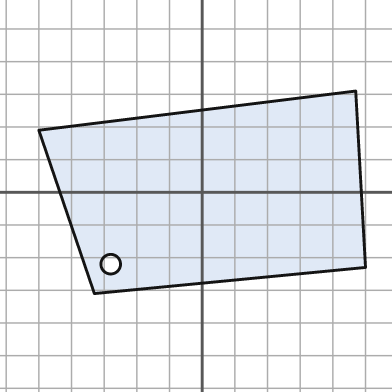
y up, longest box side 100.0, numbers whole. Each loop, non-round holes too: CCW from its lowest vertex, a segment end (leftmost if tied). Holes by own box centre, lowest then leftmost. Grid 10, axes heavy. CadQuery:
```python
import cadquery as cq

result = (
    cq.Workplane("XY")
    .moveTo(-33.0, -31.0)
    .lineTo(50.0, -23.0)
    .lineTo(47.0, 31.0)
    .lineTo(-50.0, 19.0)
    .close()
    .moveTo(-28.0, -22.0)
    .circle(3.0)
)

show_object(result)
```